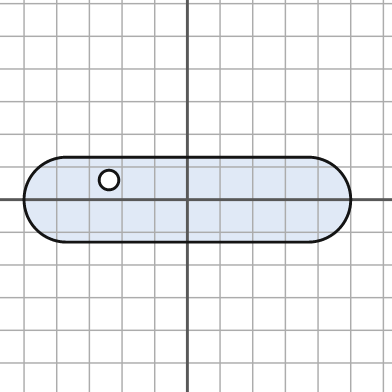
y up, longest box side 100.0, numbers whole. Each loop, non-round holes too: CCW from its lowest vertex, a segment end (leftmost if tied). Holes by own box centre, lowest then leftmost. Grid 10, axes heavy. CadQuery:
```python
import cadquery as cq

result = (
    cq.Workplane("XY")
    .moveTo(-37.0, -13.0)
    .lineTo(37.0, -13.0)
    .threePointArc((50.0, 0.0), (37.0, 13.0))
    .lineTo(-37.0, 13.0)
    .threePointArc((-50.0, 0.0), (-37.0, -13.0))
    .close()
    .moveTo(-24.0, 6.0)
    .circle(3.0)
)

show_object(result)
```